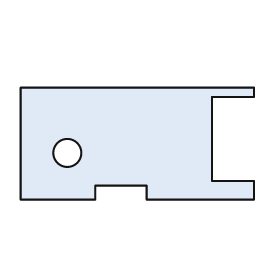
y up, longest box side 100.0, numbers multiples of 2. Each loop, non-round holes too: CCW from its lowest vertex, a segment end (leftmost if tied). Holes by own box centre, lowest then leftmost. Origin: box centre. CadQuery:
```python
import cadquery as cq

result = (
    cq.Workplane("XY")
    .moveTo(-50.0, -24.0)
    .lineTo(-18.0, -24.0)
    .lineTo(-18.0, -18.0)
    .lineTo(4.0, -18.0)
    .lineTo(4.0, -24.0)
    .lineTo(50.0, -24.0)
    .lineTo(50.0, -16.0)
    .lineTo(32.0, -16.0)
    .lineTo(32.0, 20.0)
    .lineTo(50.0, 20.0)
    .lineTo(50.0, 24.0)
    .lineTo(-50.0, 24.0)
    .close()
    .moveTo(-30.0, -4.0)
    .circle(6.0)
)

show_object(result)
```